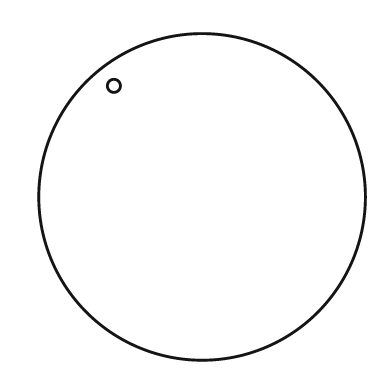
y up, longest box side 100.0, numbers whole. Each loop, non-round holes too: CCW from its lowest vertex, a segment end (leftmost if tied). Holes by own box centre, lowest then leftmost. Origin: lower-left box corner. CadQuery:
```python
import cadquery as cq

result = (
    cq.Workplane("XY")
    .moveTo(50.0, 50.0)
    .circle(50.0)
    .moveTo(23.0, 84.0)
    .circle(2.0)
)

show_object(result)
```